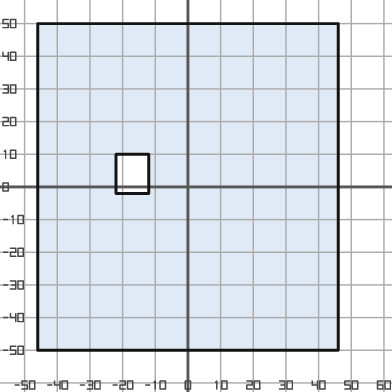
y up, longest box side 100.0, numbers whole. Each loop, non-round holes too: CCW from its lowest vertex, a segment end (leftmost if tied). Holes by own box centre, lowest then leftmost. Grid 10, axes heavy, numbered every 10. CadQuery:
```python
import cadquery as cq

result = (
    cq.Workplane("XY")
    .moveTo(-46.0, -50.0)
    .lineTo(46.0, -50.0)
    .lineTo(46.0, 50.0)
    .lineTo(-46.0, 50.0)
    .close()
    .moveTo(-22.0, -2.0)
    .lineTo(-12.0, -2.0)
    .lineTo(-12.0, 10.0)
    .lineTo(-22.0, 10.0)
    .close()
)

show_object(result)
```